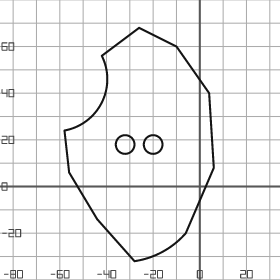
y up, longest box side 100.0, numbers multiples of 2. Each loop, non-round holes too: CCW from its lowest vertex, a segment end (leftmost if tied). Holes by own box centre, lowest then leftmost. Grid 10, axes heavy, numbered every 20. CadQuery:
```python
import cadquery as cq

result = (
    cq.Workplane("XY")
    .moveTo(-28.0, -32.0)
    .threePointArc((-16.0, -28.0), (-6.0, -20.0))
    .lineTo(6.0, 8.0)
    .lineTo(4.0, 40.0)
    .lineTo(-10.0, 60.0)
    .lineTo(-26.0, 68.0)
    .lineTo(-42.0, 56.0)
    .threePointArc((-42.0, 36.0), (-58.0, 24.0))
    .lineTo(-56.0, 6.0)
    .lineTo(-44.0, -14.0)
    .close()
    .moveTo(-32.0, 18.0)
    .circle(4.0)
    .moveTo(-20.0, 18.0)
    .circle(4.0)
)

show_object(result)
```